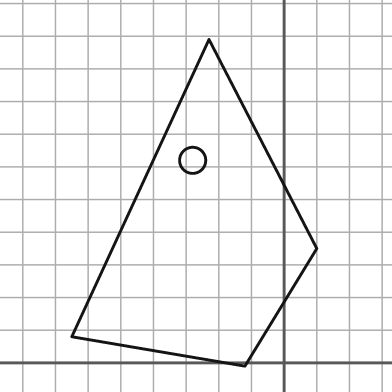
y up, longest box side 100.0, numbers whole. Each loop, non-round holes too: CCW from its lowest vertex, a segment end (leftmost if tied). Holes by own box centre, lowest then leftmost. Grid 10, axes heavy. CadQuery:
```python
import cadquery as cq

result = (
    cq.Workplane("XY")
    .moveTo(-12.0, -1.0)
    .lineTo(10.0, 35.0)
    .lineTo(-23.0, 99.0)
    .lineTo(-65.0, 8.0)
    .close()
    .moveTo(-28.0, 62.0)
    .circle(4.0)
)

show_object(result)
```